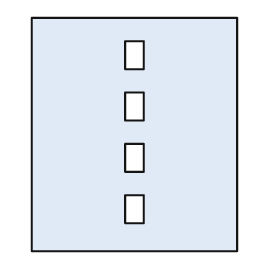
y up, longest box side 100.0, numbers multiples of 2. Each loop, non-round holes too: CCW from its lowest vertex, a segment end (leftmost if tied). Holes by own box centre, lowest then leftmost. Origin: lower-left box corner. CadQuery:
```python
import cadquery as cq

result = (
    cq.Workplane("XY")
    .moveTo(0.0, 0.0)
    .lineTo(88.0, 0.0)
    .lineTo(88.0, 100.0)
    .lineTo(0.0, 100.0)
    .close()
    .moveTo(40.0, 12.0)
    .lineTo(48.0, 12.0)
    .lineTo(48.0, 24.0)
    .lineTo(40.0, 24.0)
    .close()
    .moveTo(40.0, 34.0)
    .lineTo(48.0, 34.0)
    .lineTo(48.0, 46.0)
    .lineTo(40.0, 46.0)
    .close()
    .moveTo(40.0, 56.0)
    .lineTo(48.0, 56.0)
    .lineTo(48.0, 68.0)
    .lineTo(40.0, 68.0)
    .close()
    .moveTo(40.0, 78.0)
    .lineTo(48.0, 78.0)
    .lineTo(48.0, 90.0)
    .lineTo(40.0, 90.0)
    .close()
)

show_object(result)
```